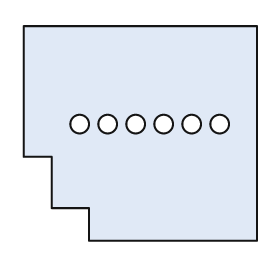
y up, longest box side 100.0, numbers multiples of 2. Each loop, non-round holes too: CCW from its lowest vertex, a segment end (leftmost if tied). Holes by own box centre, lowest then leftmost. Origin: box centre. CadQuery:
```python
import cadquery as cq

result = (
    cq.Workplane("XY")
    .moveTo(-22.0, -46.0)
    .lineTo(50.0, -46.0)
    .lineTo(50.0, 46.0)
    .lineTo(-50.0, 46.0)
    .lineTo(-50.0, -10.0)
    .lineTo(-38.0, -10.0)
    .lineTo(-38.0, -32.0)
    .lineTo(-22.0, -32.0)
    .close()
    .moveTo(-26.0, 4.0)
    .circle(4.0)
    .moveTo(-14.0, 4.0)
    .circle(4.0)
    .moveTo(-2.0, 4.0)
    .circle(4.0)
    .moveTo(10.0, 4.0)
    .circle(4.0)
    .moveTo(22.0, 4.0)
    .circle(4.0)
    .moveTo(34.0, 4.0)
    .circle(4.0)
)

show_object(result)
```